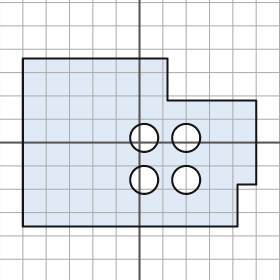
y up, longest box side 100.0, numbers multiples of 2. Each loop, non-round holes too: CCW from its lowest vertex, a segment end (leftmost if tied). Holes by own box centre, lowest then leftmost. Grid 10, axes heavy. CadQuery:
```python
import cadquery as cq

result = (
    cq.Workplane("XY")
    .moveTo(-50.0, -36.0)
    .lineTo(42.0, -36.0)
    .lineTo(42.0, -18.0)
    .lineTo(50.0, -18.0)
    .lineTo(50.0, 18.0)
    .lineTo(12.0, 18.0)
    .lineTo(12.0, 36.0)
    .lineTo(-50.0, 36.0)
    .close()
    .moveTo(2.0, -16.0)
    .circle(6.0)
    .moveTo(20.0, -16.0)
    .circle(6.0)
    .moveTo(2.0, 2.0)
    .circle(6.0)
    .moveTo(20.0, 2.0)
    .circle(6.0)
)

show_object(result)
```